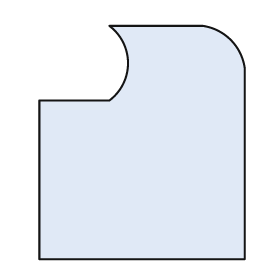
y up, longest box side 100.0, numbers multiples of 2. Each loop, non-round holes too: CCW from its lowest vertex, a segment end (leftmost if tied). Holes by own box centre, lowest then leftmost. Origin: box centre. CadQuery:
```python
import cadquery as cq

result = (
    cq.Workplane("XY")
    .moveTo(-44.0, -50.0)
    .lineTo(44.0, -50.0)
    .lineTo(44.0, 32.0)
    .threePointArc((38.0, 44.0), (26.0, 50.0))
    .lineTo(-14.0, 50.0)
    .threePointArc((-6.0, 34.0), (-14.0, 18.0))
    .lineTo(-44.0, 18.0)
    .close()
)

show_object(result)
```